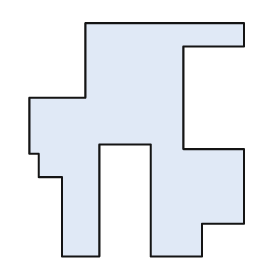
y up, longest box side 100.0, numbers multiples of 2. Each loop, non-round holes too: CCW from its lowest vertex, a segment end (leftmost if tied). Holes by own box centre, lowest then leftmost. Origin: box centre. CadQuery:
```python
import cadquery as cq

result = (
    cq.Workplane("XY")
    .moveTo(-32.0, -50.0)
    .lineTo(-16.0, -50.0)
    .lineTo(-16.0, -2.0)
    .lineTo(6.0, -2.0)
    .lineTo(6.0, -50.0)
    .lineTo(28.0, -50.0)
    .lineTo(28.0, -36.0)
    .lineTo(46.0, -36.0)
    .lineTo(46.0, -4.0)
    .lineTo(20.0, -4.0)
    .lineTo(20.0, 40.0)
    .lineTo(46.0, 40.0)
    .lineTo(46.0, 50.0)
    .lineTo(-22.0, 50.0)
    .lineTo(-22.0, 18.0)
    .lineTo(-46.0, 18.0)
    .lineTo(-46.0, -6.0)
    .lineTo(-42.0, -6.0)
    .lineTo(-42.0, -16.0)
    .lineTo(-32.0, -16.0)
    .close()
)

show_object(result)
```